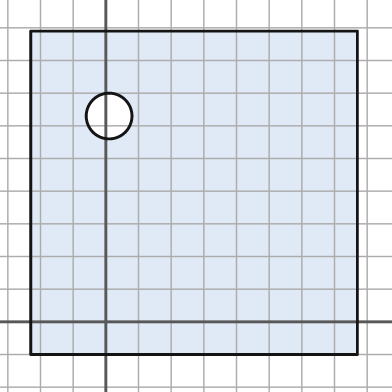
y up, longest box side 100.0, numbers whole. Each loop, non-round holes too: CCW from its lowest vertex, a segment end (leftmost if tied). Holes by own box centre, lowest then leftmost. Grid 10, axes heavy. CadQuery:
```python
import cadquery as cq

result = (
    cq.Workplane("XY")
    .moveTo(-23.0, -10.0)
    .lineTo(77.0, -10.0)
    .lineTo(77.0, 89.0)
    .lineTo(-23.0, 89.0)
    .close()
    .moveTo(1.0, 63.0)
    .circle(7.0)
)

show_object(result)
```